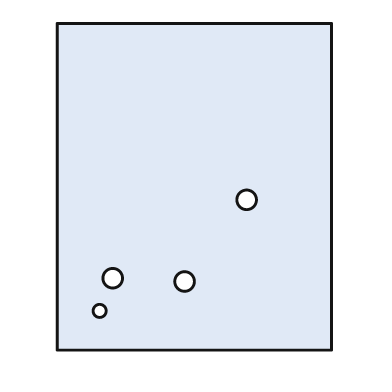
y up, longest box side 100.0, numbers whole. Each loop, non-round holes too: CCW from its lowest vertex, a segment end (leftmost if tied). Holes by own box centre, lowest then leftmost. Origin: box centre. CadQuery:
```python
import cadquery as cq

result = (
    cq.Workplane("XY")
    .moveTo(-42.0, -50.0)
    .lineTo(42.0, -50.0)
    .lineTo(42.0, 50.0)
    .lineTo(-42.0, 50.0)
    .close()
    .moveTo(-29.0, -38.0)
    .circle(2.0)
    .moveTo(-3.0, -29.0)
    .circle(3.0)
    .moveTo(-25.0, -28.0)
    .circle(3.0)
    .moveTo(16.0, -4.0)
    .circle(3.0)
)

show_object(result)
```